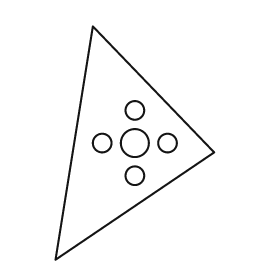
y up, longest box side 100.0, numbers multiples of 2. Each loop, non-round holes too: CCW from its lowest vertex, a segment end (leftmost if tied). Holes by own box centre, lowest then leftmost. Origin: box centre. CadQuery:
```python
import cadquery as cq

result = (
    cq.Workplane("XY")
    .moveTo(-34.0, -50.0)
    .lineTo(34.0, -4.0)
    .lineTo(-18.0, 50.0)
    .close()
    .moveTo(0.0, -14.0)
    .circle(4.0)
    .moveTo(-14.0, 0.0)
    .circle(4.0)
    .moveTo(0.0, 0.0)
    .circle(6.0)
    .moveTo(14.0, 0.0)
    .circle(4.0)
    .moveTo(0.0, 14.0)
    .circle(4.0)
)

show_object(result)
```